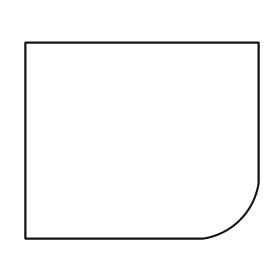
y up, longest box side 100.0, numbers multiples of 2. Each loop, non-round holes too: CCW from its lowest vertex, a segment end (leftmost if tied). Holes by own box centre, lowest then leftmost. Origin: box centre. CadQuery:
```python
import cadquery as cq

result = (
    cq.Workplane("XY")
    .moveTo(-50.0, -42.0)
    .lineTo(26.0, -42.0)
    .threePointArc((42.0, -34.0), (50.0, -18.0))
    .lineTo(50.0, 42.0)
    .lineTo(-50.0, 42.0)
    .close()
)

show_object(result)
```